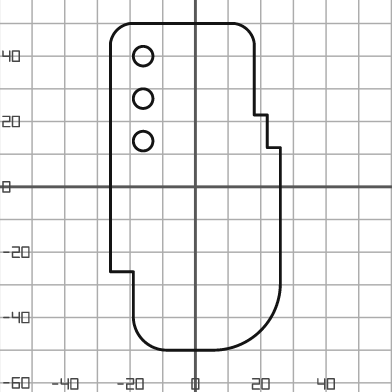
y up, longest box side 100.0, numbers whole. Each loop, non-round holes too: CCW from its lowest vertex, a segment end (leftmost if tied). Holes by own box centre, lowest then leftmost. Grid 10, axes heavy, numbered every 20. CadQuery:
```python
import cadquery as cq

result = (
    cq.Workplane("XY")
    .moveTo(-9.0, -50.0)
    .lineTo(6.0, -50.0)
    .threePointArc((20.0, -44.0), (26.0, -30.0))
    .lineTo(26.0, 12.0)
    .lineTo(22.0, 12.0)
    .lineTo(22.0, 22.0)
    .lineTo(18.0, 22.0)
    .lineTo(18.0, 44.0)
    .threePointArc((16.0, 48.0), (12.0, 50.0))
    .lineTo(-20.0, 50.0)
    .threePointArc((-24.0, 48.0), (-26.0, 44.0))
    .lineTo(-26.0, -26.0)
    .lineTo(-19.0, -26.0)
    .lineTo(-19.0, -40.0)
    .threePointArc((-16.0, -47.0), (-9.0, -50.0))
    .close()
    .moveTo(-16.0, 14.0)
    .circle(3.0)
    .moveTo(-16.0, 27.0)
    .circle(3.0)
    .moveTo(-16.0, 40.0)
    .circle(3.0)
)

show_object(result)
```